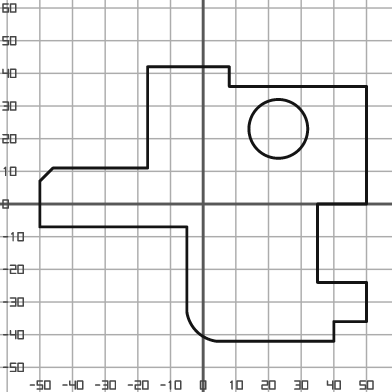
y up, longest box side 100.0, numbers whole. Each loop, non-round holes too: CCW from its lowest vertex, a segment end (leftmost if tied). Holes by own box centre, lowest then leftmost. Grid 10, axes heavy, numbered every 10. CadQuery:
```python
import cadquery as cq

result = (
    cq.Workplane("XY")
    .moveTo(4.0, -42.0)
    .lineTo(40.0, -42.0)
    .lineTo(40.0, -36.0)
    .lineTo(50.0, -36.0)
    .lineTo(50.0, -24.0)
    .lineTo(35.0, -24.0)
    .lineTo(35.0, 0.0)
    .lineTo(50.0, 0.0)
    .lineTo(50.0, 36.0)
    .lineTo(8.0, 36.0)
    .lineTo(8.0, 42.0)
    .lineTo(-17.0, 42.0)
    .lineTo(-17.0, 11.0)
    .lineTo(-46.0, 11.0)
    .lineTo(-50.0, 7.0)
    .lineTo(-50.0, -7.0)
    .lineTo(-5.0, -7.0)
    .lineTo(-5.0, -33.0)
    .threePointArc((-2.0, -39.0), (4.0, -42.0))
    .close()
    .moveTo(23.0, 23.0)
    .circle(9.0)
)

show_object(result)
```